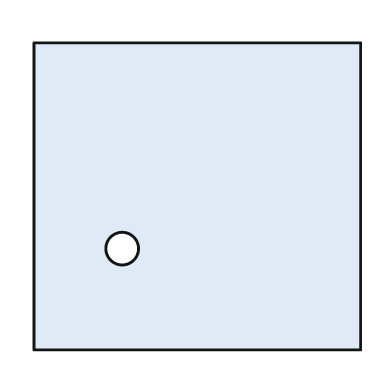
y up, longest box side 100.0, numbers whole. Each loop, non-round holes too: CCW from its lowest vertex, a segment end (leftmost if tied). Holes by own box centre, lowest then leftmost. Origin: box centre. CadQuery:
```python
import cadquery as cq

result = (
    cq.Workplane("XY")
    .moveTo(-50.0, -47.0)
    .lineTo(50.0, -47.0)
    .lineTo(50.0, 47.0)
    .lineTo(-50.0, 47.0)
    .close()
    .moveTo(-23.0, -16.0)
    .circle(5.0)
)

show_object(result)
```